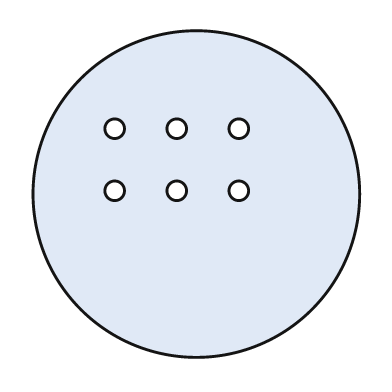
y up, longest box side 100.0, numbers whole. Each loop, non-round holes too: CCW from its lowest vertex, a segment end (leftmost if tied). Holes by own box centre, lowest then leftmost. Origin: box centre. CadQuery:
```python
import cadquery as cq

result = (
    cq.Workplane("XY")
    .moveTo(0.0, 0.0)
    .circle(50.0)
    .moveTo(-25.0, 1.0)
    .circle(3.0)
    .moveTo(-6.0, 1.0)
    .circle(3.0)
    .moveTo(13.0, 1.0)
    .circle(3.0)
    .moveTo(-25.0, 20.0)
    .circle(3.0)
    .moveTo(-6.0, 20.0)
    .circle(3.0)
    .moveTo(13.0, 20.0)
    .circle(3.0)
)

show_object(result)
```